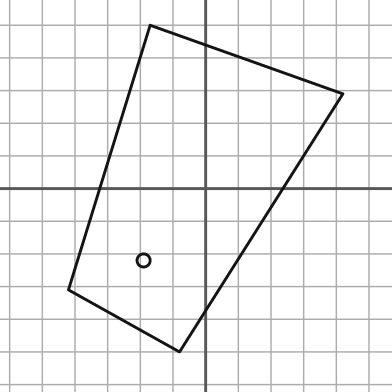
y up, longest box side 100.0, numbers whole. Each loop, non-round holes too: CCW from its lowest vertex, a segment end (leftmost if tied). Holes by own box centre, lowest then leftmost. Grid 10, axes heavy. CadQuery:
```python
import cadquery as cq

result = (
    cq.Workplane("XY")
    .moveTo(-8.0, -50.0)
    .lineTo(42.0, 29.0)
    .lineTo(-17.0, 50.0)
    .lineTo(-42.0, -31.0)
    .close()
    .moveTo(-19.0, -22.0)
    .circle(2.0)
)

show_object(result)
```